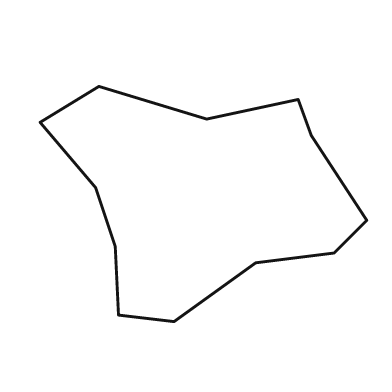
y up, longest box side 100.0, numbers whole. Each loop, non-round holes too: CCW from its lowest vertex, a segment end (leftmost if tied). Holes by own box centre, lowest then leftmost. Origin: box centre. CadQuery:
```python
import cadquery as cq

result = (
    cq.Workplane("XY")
    .moveTo(-9.0, -36.0)
    .lineTo(16.0, -18.0)
    .lineTo(40.0, -15.0)
    .lineTo(50.0, -5.0)
    .lineTo(33.0, 21.0)
    .lineTo(29.0, 32.0)
    .lineTo(1.0, 26.0)
    .lineTo(-32.0, 36.0)
    .lineTo(-50.0, 25.0)
    .lineTo(-33.0, 5.0)
    .lineTo(-27.0, -13.0)
    .lineTo(-26.0, -34.0)
    .close()
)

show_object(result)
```